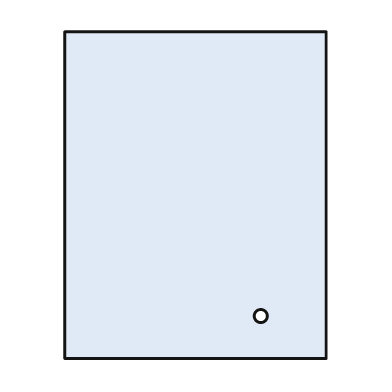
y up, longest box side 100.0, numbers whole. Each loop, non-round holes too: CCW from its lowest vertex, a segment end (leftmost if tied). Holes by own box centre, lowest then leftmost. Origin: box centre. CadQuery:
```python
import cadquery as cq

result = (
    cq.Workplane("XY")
    .moveTo(-40.0, -50.0)
    .lineTo(40.0, -50.0)
    .lineTo(40.0, 50.0)
    .lineTo(-40.0, 50.0)
    .close()
    .moveTo(20.0, -37.0)
    .circle(2.0)
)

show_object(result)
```